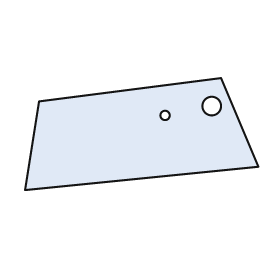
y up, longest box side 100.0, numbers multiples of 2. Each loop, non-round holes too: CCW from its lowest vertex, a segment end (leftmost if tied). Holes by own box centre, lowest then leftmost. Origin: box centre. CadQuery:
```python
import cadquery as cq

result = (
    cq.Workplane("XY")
    .moveTo(-50.0, -24.0)
    .lineTo(50.0, -14.0)
    .lineTo(34.0, 24.0)
    .lineTo(-44.0, 14.0)
    .close()
    .moveTo(10.0, 8.0)
    .circle(2.0)
    .moveTo(30.0, 12.0)
    .circle(4.0)
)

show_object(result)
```